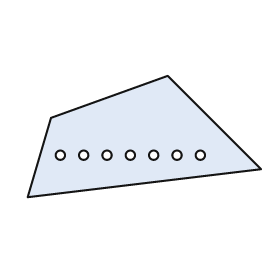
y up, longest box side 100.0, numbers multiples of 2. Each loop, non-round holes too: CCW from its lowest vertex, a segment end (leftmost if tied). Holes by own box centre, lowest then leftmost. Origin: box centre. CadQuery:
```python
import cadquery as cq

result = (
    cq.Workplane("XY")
    .moveTo(-50.0, -26.0)
    .lineTo(50.0, -14.0)
    .lineTo(10.0, 26.0)
    .lineTo(-40.0, 8.0)
    .close()
    .moveTo(-36.0, -8.0)
    .circle(2.0)
    .moveTo(-26.0, -8.0)
    .circle(2.0)
    .moveTo(-16.0, -8.0)
    .circle(2.0)
    .moveTo(-6.0, -8.0)
    .circle(2.0)
    .moveTo(4.0, -8.0)
    .circle(2.0)
    .moveTo(14.0, -8.0)
    .circle(2.0)
    .moveTo(24.0, -8.0)
    .circle(2.0)
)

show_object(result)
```